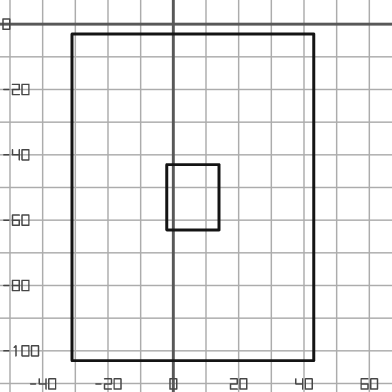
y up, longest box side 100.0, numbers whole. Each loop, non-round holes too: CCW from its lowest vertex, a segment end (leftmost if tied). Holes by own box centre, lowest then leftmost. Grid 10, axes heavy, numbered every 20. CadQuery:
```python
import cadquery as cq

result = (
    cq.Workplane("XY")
    .moveTo(-31.0, -103.0)
    .lineTo(43.0, -103.0)
    .lineTo(43.0, -3.0)
    .lineTo(-31.0, -3.0)
    .close()
    .moveTo(-2.0, -63.0)
    .lineTo(14.0, -63.0)
    .lineTo(14.0, -43.0)
    .lineTo(-2.0, -43.0)
    .close()
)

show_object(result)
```